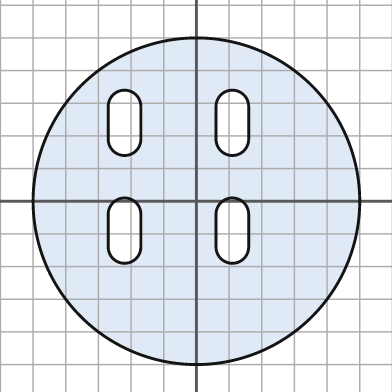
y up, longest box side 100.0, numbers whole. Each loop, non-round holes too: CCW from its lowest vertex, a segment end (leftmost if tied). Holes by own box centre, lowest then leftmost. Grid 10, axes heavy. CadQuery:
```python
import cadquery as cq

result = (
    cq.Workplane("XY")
    .moveTo(0.0, 0.0)
    .circle(50.0)
    .moveTo(-27.0, -14.0)
    .threePointArc((-22.0, -19.0), (-17.0, -14.0))
    .lineTo(-17.0, -4.0)
    .threePointArc((-22.0, 1.0), (-27.0, -4.0))
    .close()
    .moveTo(6.0, -14.0)
    .threePointArc((11.0, -19.0), (16.0, -14.0))
    .lineTo(16.0, -4.0)
    .threePointArc((11.0, 1.0), (6.0, -4.0))
    .close()
    .moveTo(-27.0, 19.0)
    .threePointArc((-22.0, 14.0), (-17.0, 19.0))
    .lineTo(-17.0, 29.0)
    .threePointArc((-22.0, 34.0), (-27.0, 29.0))
    .close()
    .moveTo(6.0, 19.0)
    .threePointArc((11.0, 14.0), (16.0, 19.0))
    .lineTo(16.0, 29.0)
    .threePointArc((11.0, 34.0), (6.0, 29.0))
    .close()
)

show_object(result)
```